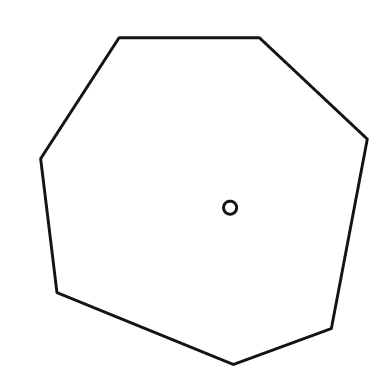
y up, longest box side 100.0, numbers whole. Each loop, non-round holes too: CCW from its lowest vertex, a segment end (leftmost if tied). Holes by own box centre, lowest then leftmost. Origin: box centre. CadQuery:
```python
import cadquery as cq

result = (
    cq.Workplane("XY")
    .moveTo(9.0, -50.0)
    .lineTo(39.0, -39.0)
    .lineTo(50.0, 19.0)
    .lineTo(17.0, 50.0)
    .lineTo(-26.0, 50.0)
    .lineTo(-50.0, 13.0)
    .lineTo(-45.0, -28.0)
    .close()
    .moveTo(8.0, -2.0)
    .circle(2.0)
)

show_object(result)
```